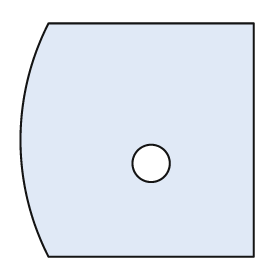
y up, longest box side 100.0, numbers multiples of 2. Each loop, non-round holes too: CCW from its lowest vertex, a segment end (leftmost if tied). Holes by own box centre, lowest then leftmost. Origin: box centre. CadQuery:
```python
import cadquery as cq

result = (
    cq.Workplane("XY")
    .moveTo(-38.0, -50.0)
    .lineTo(50.0, -50.0)
    .lineTo(50.0, 50.0)
    .lineTo(-38.0, 50.0)
    .threePointArc((-50.0, 0.0), (-38.0, -50.0))
    .close()
    .moveTo(6.0, -10.0)
    .circle(8.0)
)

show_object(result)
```